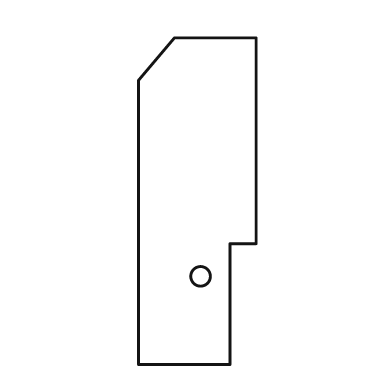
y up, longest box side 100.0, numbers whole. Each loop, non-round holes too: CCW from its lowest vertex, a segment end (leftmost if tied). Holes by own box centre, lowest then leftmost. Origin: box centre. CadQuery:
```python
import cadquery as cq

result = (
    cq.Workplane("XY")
    .moveTo(-18.0, -50.0)
    .lineTo(10.0, -50.0)
    .lineTo(10.0, -13.0)
    .lineTo(18.0, -13.0)
    .lineTo(18.0, 50.0)
    .lineTo(-7.0, 50.0)
    .lineTo(-18.0, 37.0)
    .close()
    .moveTo(1.0, -23.0)
    .circle(3.0)
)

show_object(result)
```